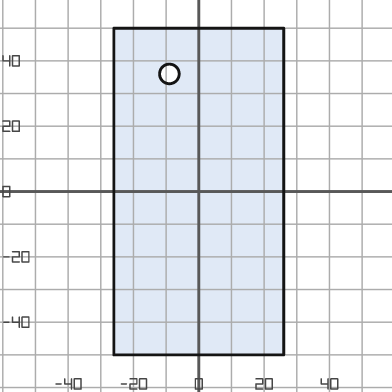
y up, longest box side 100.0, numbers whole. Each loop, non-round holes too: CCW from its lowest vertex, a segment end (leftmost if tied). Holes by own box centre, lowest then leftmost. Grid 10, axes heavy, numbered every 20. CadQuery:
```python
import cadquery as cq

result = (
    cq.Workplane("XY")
    .moveTo(-26.0, -50.0)
    .lineTo(26.0, -50.0)
    .lineTo(26.0, 50.0)
    .lineTo(-26.0, 50.0)
    .close()
    .moveTo(-9.0, 36.0)
    .circle(3.0)
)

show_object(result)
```